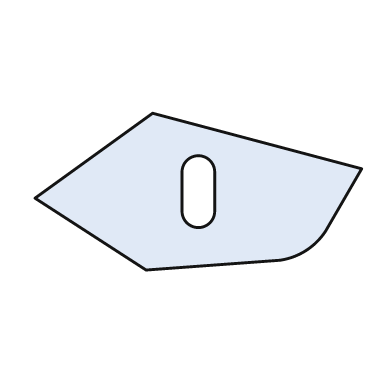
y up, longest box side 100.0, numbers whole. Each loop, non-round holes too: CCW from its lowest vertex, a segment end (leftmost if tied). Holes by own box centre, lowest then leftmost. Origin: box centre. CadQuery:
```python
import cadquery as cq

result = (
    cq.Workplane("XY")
    .moveTo(-16.0, -24.0)
    .lineTo(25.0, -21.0)
    .threePointArc((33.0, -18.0), (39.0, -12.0))
    .lineTo(50.0, 7.0)
    .lineTo(-14.0, 24.0)
    .lineTo(-50.0, -2.0)
    .close()
    .moveTo(-5.0, -6.0)
    .threePointArc((0.0, -11.0), (5.0, -6.0))
    .lineTo(5.0, 6.0)
    .threePointArc((0.0, 11.0), (-5.0, 6.0))
    .close()
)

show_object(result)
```